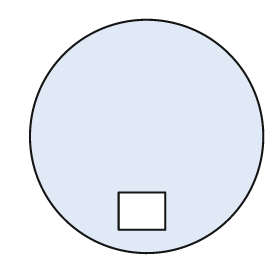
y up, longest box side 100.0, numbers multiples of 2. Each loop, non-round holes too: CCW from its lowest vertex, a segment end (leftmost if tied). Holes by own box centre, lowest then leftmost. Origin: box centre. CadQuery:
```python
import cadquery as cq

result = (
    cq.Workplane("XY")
    .moveTo(0.0, 0.0)
    .circle(50.0)
    .moveTo(-12.0, -40.0)
    .lineTo(8.0, -40.0)
    .lineTo(8.0, -24.0)
    .lineTo(-12.0, -24.0)
    .close()
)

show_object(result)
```